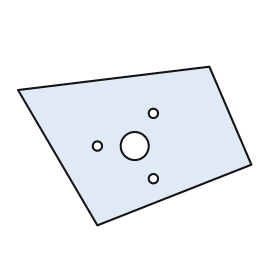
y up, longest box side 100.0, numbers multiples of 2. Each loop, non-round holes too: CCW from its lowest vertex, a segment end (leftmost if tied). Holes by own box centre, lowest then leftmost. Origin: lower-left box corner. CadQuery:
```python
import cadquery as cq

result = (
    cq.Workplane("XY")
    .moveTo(34.0, 0.0)
    .lineTo(100.0, 26.0)
    .lineTo(82.0, 68.0)
    .lineTo(0.0, 58.0)
    .close()
    .moveTo(58.0, 20.0)
    .circle(2.0)
    .moveTo(34.0, 34.0)
    .circle(2.0)
    .moveTo(50.0, 34.0)
    .circle(6.0)
    .moveTo(58.0, 48.0)
    .circle(2.0)
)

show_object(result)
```